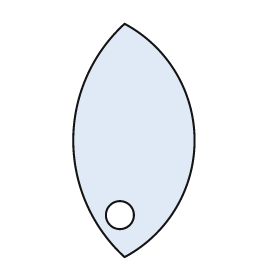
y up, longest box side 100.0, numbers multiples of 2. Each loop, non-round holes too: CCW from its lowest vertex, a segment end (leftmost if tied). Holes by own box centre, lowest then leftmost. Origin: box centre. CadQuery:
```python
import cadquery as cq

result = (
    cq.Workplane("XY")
    .moveTo(-4.0, -50.0)
    .threePointArc((26.0, 0.0), (-4.0, 50.0))
    .threePointArc((-26.0, 0.0), (-4.0, -50.0))
    .close()
    .moveTo(-6.0, -32.0)
    .circle(6.0)
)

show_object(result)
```